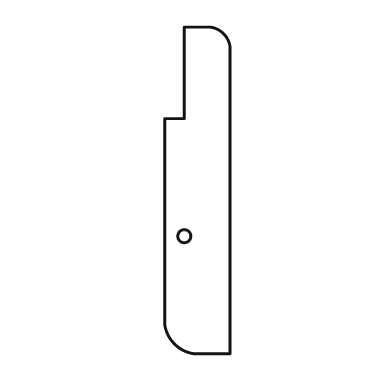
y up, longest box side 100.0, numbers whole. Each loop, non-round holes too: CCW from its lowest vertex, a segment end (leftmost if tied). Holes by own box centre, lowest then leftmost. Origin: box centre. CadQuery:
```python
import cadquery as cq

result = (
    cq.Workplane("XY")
    .moveTo(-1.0, -50.0)
    .lineTo(10.0, -50.0)
    .lineTo(10.0, 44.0)
    .threePointArc((8.0, 48.0), (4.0, 50.0))
    .lineTo(-4.0, 50.0)
    .lineTo(-4.0, 22.0)
    .lineTo(-10.0, 22.0)
    .lineTo(-10.0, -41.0)
    .threePointArc((-7.0, -47.0), (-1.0, -50.0))
    .close()
    .moveTo(-4.0, -14.0)
    .circle(2.0)
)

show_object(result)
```